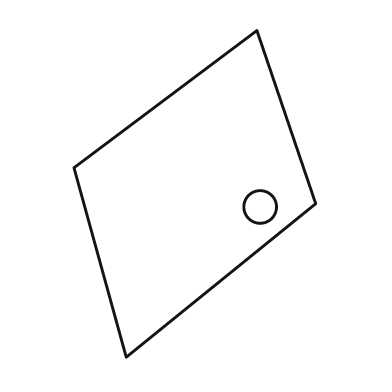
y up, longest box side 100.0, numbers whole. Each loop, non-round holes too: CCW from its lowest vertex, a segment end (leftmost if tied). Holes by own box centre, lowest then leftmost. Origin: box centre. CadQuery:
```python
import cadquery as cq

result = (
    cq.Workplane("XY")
    .moveTo(-21.0, -50.0)
    .lineTo(37.0, -3.0)
    .lineTo(19.0, 50.0)
    .lineTo(-37.0, 8.0)
    .close()
    .moveTo(20.0, -4.0)
    .circle(5.0)
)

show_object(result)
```